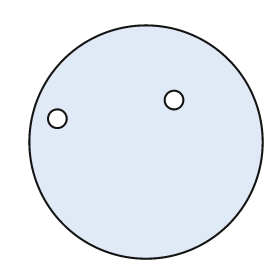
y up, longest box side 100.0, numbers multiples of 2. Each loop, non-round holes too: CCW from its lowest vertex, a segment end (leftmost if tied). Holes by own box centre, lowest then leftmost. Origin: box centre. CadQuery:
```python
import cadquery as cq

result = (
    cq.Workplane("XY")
    .moveTo(0.0, 0.0)
    .circle(50.0)
    .moveTo(-38.0, 10.0)
    .circle(4.0)
    .moveTo(12.0, 18.0)
    .circle(4.0)
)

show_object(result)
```